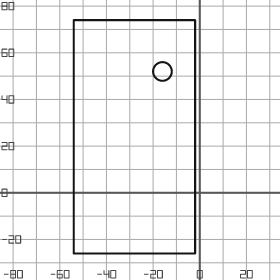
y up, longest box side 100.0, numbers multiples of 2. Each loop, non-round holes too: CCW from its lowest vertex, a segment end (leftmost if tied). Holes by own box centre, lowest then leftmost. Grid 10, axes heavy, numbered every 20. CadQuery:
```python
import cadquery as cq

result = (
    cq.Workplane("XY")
    .moveTo(-54.0, -26.0)
    .lineTo(-2.0, -26.0)
    .lineTo(-2.0, 74.0)
    .lineTo(-54.0, 74.0)
    .close()
    .moveTo(-16.0, 52.0)
    .circle(4.0)
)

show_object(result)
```